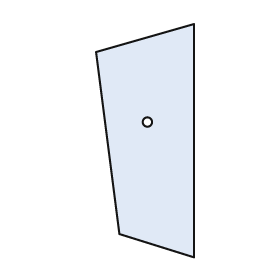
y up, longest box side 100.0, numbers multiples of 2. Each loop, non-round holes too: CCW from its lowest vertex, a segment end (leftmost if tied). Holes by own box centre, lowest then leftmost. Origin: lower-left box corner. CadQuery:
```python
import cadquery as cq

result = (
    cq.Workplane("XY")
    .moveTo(42.0, 0.0)
    .lineTo(42.0, 100.0)
    .lineTo(0.0, 88.0)
    .lineTo(10.0, 10.0)
    .close()
    .moveTo(22.0, 58.0)
    .circle(2.0)
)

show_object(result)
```